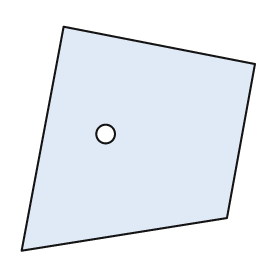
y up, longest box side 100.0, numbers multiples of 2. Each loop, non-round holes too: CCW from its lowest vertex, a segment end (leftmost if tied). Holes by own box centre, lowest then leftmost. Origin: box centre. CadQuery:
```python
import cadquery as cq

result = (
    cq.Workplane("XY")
    .moveTo(-50.0, -48.0)
    .lineTo(38.0, -34.0)
    .lineTo(50.0, 32.0)
    .lineTo(-32.0, 48.0)
    .close()
    .moveTo(-14.0, 2.0)
    .circle(4.0)
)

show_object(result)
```